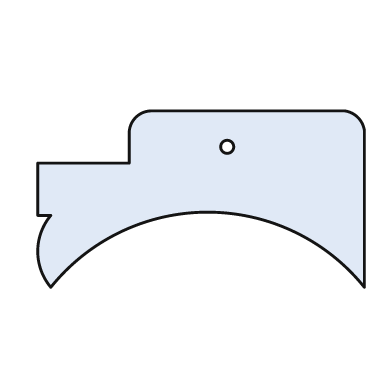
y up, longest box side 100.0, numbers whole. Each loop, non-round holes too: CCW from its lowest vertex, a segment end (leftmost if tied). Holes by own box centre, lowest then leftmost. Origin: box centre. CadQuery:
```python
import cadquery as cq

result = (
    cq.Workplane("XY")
    .moveTo(-46.0, -27.0)
    .threePointArc((2.0, -4.0), (50.0, -27.0))
    .lineTo(50.0, 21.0)
    .threePointArc((48.0, 25.0), (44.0, 27.0))
    .lineTo(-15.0, 27.0)
    .threePointArc((-20.0, 25.0), (-22.0, 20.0))
    .lineTo(-22.0, 11.0)
    .lineTo(-50.0, 11.0)
    .lineTo(-50.0, -5.0)
    .lineTo(-46.0, -5.0)
    .threePointArc((-50.0, -16.0), (-46.0, -27.0))
    .close()
    .moveTo(8.0, 16.0)
    .circle(2.0)
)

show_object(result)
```